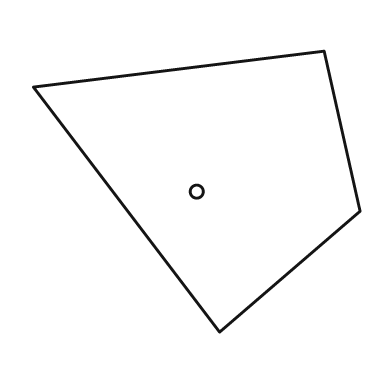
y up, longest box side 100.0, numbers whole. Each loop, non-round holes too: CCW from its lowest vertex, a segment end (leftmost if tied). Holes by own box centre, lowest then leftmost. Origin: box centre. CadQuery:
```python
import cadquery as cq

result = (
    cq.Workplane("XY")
    .moveTo(7.0, -43.0)
    .lineTo(50.0, -6.0)
    .lineTo(39.0, 43.0)
    .lineTo(-50.0, 32.0)
    .close()
    .moveTo(0.0, 0.0)
    .circle(2.0)
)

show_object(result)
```